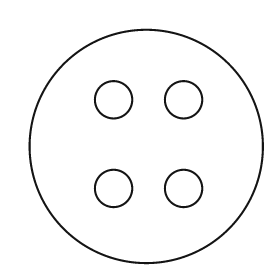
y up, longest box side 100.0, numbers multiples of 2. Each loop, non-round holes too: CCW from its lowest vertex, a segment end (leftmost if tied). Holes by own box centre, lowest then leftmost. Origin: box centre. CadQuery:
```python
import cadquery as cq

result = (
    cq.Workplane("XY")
    .moveTo(0.0, 0.0)
    .circle(50.0)
    .moveTo(-14.0, -18.0)
    .circle(8.0)
    .moveTo(16.0, -18.0)
    .circle(8.0)
    .moveTo(-14.0, 20.0)
    .circle(8.0)
    .moveTo(16.0, 20.0)
    .circle(8.0)
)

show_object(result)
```